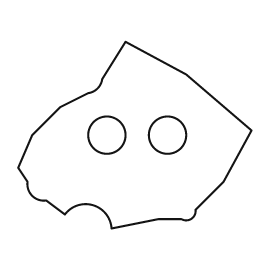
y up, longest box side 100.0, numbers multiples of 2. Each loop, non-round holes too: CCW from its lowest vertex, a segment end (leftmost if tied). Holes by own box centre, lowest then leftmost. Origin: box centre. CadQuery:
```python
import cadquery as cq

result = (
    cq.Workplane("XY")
    .moveTo(-10.0, -40.0)
    .lineTo(10.0, -36.0)
    .lineTo(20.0, -36.0)
    .threePointArc((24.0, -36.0), (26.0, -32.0))
    .lineTo(38.0, -20.0)
    .lineTo(50.0, 2.0)
    .lineTo(22.0, 26.0)
    .lineTo(-4.0, 40.0)
    .lineTo(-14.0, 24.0)
    .threePointArc((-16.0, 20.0), (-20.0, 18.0))
    .lineTo(-32.0, 12.0)
    .lineTo(-44.0, 0.0)
    .lineTo(-50.0, -14.0)
    .lineTo(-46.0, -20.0)
    .threePointArc((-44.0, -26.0), (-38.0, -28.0))
    .lineTo(-30.0, -34.0)
    .threePointArc((-18.0, -30.0), (-10.0, -40.0))
    .close()
    .moveTo(-12.0, 0.0)
    .circle(8.0)
    .moveTo(14.0, 0.0)
    .circle(8.0)
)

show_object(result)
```